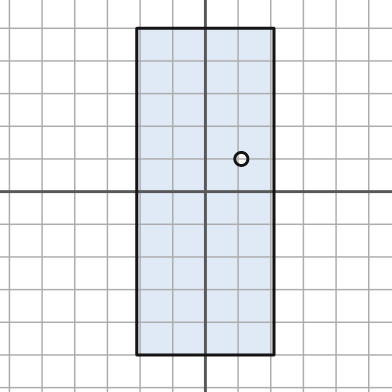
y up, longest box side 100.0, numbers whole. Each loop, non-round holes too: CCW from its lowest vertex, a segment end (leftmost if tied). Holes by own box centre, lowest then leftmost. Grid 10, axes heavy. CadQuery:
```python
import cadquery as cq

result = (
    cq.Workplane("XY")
    .moveTo(-21.0, -50.0)
    .lineTo(21.0, -50.0)
    .lineTo(21.0, 50.0)
    .lineTo(-21.0, 50.0)
    .close()
    .moveTo(11.0, 10.0)
    .circle(2.0)
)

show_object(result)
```